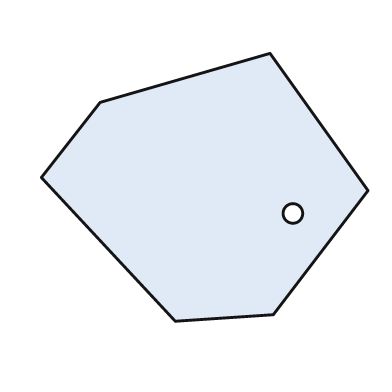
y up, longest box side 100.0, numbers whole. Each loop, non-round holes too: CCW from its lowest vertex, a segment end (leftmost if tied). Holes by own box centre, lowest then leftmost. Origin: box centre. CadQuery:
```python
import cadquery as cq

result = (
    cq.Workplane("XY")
    .moveTo(-9.0, -41.0)
    .lineTo(21.0, -39.0)
    .lineTo(50.0, -1.0)
    .lineTo(20.0, 41.0)
    .lineTo(-32.0, 26.0)
    .lineTo(-50.0, 3.0)
    .close()
    .moveTo(27.0, -8.0)
    .circle(3.0)
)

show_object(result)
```